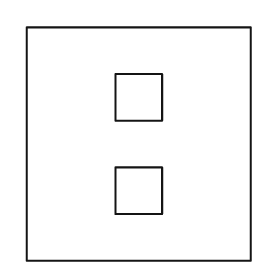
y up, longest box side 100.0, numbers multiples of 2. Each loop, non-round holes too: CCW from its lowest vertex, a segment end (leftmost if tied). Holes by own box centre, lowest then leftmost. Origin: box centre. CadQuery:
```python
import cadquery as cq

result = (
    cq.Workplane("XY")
    .moveTo(-48.0, -50.0)
    .lineTo(48.0, -50.0)
    .lineTo(48.0, 50.0)
    .lineTo(-48.0, 50.0)
    .close()
    .moveTo(-10.0, -30.0)
    .lineTo(10.0, -30.0)
    .lineTo(10.0, -10.0)
    .lineTo(-10.0, -10.0)
    .close()
    .moveTo(-10.0, 10.0)
    .lineTo(10.0, 10.0)
    .lineTo(10.0, 30.0)
    .lineTo(-10.0, 30.0)
    .close()
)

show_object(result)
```